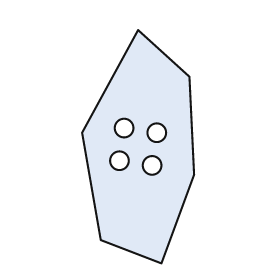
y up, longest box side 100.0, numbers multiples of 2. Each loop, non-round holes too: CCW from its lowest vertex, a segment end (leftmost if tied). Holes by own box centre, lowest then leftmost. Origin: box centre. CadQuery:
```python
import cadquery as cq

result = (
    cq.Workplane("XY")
    .moveTo(10.0, -50.0)
    .lineTo(24.0, -12.0)
    .lineTo(22.0, 30.0)
    .lineTo(0.0, 50.0)
    .lineTo(-24.0, 6.0)
    .lineTo(-16.0, -40.0)
    .close()
    .moveTo(6.0, -8.0)
    .circle(4.0)
    .moveTo(-8.0, -6.0)
    .circle(4.0)
    .moveTo(8.0, 6.0)
    .circle(4.0)
    .moveTo(-6.0, 8.0)
    .circle(4.0)
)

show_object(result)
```